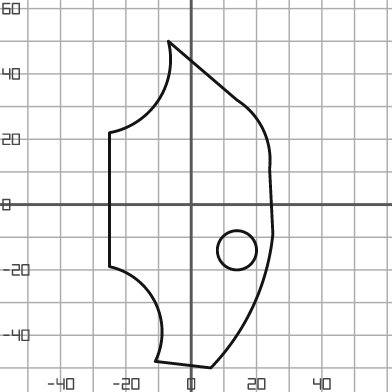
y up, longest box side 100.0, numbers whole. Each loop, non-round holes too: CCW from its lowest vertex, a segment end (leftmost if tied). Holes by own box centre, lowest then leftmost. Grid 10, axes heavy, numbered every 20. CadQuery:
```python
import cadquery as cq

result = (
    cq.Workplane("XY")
    .moveTo(6.0, -50.0)
    .threePointArc((19.0, -31.0), (25.0, -9.0))
    .lineTo(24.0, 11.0)
    .threePointArc((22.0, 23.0), (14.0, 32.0))
    .lineTo(-7.0, 50.0)
    .threePointArc((-10.0, 32.0), (-25.0, 22.0))
    .lineTo(-25.0, -19.0)
    .threePointArc((-11.0, -30.0), (-11.0, -48.0))
    .close()
    .moveTo(14.0, -14.0)
    .circle(6.0)
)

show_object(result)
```